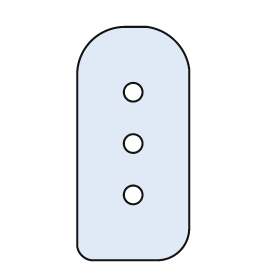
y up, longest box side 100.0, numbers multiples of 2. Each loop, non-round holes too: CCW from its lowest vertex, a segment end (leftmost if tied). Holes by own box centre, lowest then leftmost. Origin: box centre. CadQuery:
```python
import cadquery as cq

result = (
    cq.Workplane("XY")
    .moveTo(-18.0, -50.0)
    .lineTo(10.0, -50.0)
    .threePointArc((20.0, -46.0), (24.0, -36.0))
    .lineTo(24.0, 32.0)
    .threePointArc((18.0, 44.0), (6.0, 50.0))
    .lineTo(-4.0, 50.0)
    .threePointArc((-18.0, 44.0), (-24.0, 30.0))
    .lineTo(-24.0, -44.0)
    .threePointArc((-22.0, -48.0), (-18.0, -50.0))
    .close()
    .moveTo(0.0, -22.0)
    .circle(4.0)
    .moveTo(0.0, 0.0)
    .circle(4.0)
    .moveTo(0.0, 22.0)
    .circle(4.0)
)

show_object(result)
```